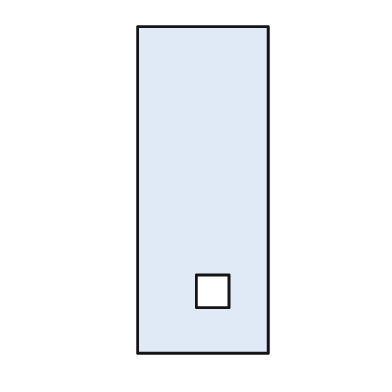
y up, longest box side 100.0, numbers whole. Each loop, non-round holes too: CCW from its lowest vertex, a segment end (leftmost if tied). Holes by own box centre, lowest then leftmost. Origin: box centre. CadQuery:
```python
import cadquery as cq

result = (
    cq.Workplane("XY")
    .moveTo(-20.0, -50.0)
    .lineTo(20.0, -50.0)
    .lineTo(20.0, 50.0)
    .lineTo(-20.0, 50.0)
    .close()
    .moveTo(-2.0, -36.0)
    .lineTo(8.0, -36.0)
    .lineTo(8.0, -26.0)
    .lineTo(-2.0, -26.0)
    .close()
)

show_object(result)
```